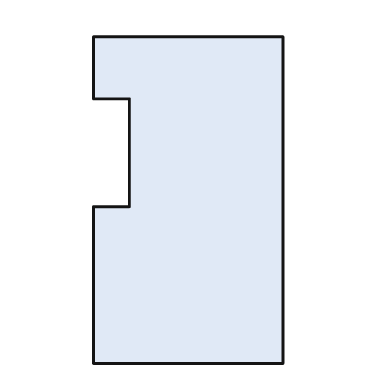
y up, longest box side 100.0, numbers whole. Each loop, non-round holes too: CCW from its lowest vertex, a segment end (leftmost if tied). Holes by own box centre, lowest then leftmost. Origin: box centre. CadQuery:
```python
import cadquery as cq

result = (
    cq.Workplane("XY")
    .moveTo(-29.0, -50.0)
    .lineTo(29.0, -50.0)
    .lineTo(29.0, 50.0)
    .lineTo(-29.0, 50.0)
    .lineTo(-29.0, 31.0)
    .lineTo(-18.0, 31.0)
    .lineTo(-18.0, -2.0)
    .lineTo(-29.0, -2.0)
    .close()
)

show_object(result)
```